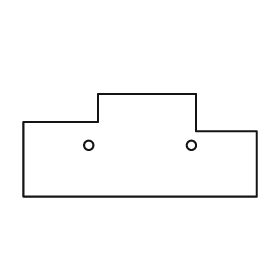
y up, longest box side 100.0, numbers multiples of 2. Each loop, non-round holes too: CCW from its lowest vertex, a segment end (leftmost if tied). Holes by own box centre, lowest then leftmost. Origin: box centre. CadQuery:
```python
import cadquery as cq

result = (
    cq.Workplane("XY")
    .moveTo(-50.0, -22.0)
    .lineTo(50.0, -22.0)
    .lineTo(50.0, 6.0)
    .lineTo(24.0, 6.0)
    .lineTo(24.0, 22.0)
    .lineTo(-18.0, 22.0)
    .lineTo(-18.0, 10.0)
    .lineTo(-50.0, 10.0)
    .close()
    .moveTo(-22.0, 0.0)
    .circle(2.0)
    .moveTo(22.0, 0.0)
    .circle(2.0)
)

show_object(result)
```